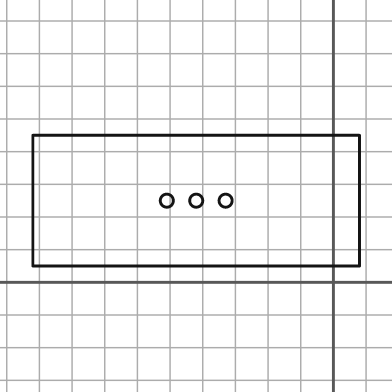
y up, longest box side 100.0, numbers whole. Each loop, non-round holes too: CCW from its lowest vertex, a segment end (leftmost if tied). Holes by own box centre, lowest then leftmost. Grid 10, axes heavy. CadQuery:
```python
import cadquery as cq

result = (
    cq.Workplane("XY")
    .moveTo(-92.0, 5.0)
    .lineTo(8.0, 5.0)
    .lineTo(8.0, 45.0)
    .lineTo(-92.0, 45.0)
    .close()
    .moveTo(-51.0, 25.0)
    .circle(2.0)
    .moveTo(-42.0, 25.0)
    .circle(2.0)
    .moveTo(-33.0, 25.0)
    .circle(2.0)
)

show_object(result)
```